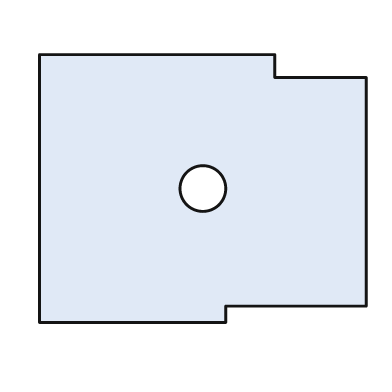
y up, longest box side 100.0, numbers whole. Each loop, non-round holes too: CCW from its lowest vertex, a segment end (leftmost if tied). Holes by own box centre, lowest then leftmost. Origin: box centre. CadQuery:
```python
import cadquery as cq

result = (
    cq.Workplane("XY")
    .moveTo(-50.0, -41.0)
    .lineTo(7.0, -41.0)
    .lineTo(7.0, -36.0)
    .lineTo(50.0, -36.0)
    .lineTo(50.0, 34.0)
    .lineTo(22.0, 34.0)
    .lineTo(22.0, 41.0)
    .lineTo(-50.0, 41.0)
    .close()
    .moveTo(0.0, 0.0)
    .circle(7.0)
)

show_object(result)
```